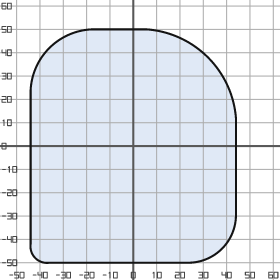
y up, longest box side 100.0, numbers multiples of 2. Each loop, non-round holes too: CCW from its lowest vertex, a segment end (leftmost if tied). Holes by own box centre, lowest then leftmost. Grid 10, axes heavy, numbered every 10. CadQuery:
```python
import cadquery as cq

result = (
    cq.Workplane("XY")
    .moveTo(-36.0, -50.0)
    .lineTo(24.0, -50.0)
    .threePointArc((38.0, -44.0), (44.0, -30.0))
    .lineTo(44.0, 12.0)
    .threePointArc((32.0, 38.0), (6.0, 50.0))
    .lineTo(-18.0, 50.0)
    .threePointArc((-36.0, 42.0), (-44.0, 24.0))
    .lineTo(-44.0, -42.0)
    .threePointArc((-42.0, -48.0), (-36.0, -50.0))
    .close()
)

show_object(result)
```